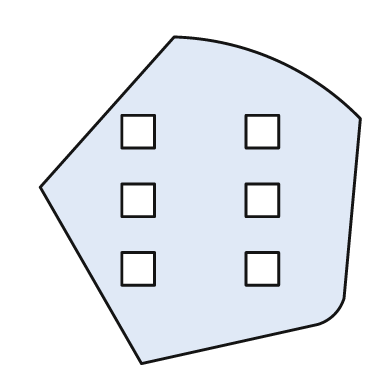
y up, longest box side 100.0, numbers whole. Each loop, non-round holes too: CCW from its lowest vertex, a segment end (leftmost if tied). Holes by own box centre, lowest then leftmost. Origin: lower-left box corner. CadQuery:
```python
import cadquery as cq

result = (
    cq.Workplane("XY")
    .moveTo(31.0, 0.0)
    .lineTo(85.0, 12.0)
    .threePointArc((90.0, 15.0), (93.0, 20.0))
    .lineTo(98.0, 75.0)
    .threePointArc((72.0, 93.0), (41.0, 100.0))
    .lineTo(0.0, 54.0)
    .close()
    .moveTo(25.0, 24.0)
    .lineTo(35.0, 24.0)
    .lineTo(35.0, 34.0)
    .lineTo(25.0, 34.0)
    .close()
    .moveTo(63.0, 24.0)
    .lineTo(73.0, 24.0)
    .lineTo(73.0, 34.0)
    .lineTo(63.0, 34.0)
    .close()
    .moveTo(25.0, 45.0)
    .lineTo(35.0, 45.0)
    .lineTo(35.0, 55.0)
    .lineTo(25.0, 55.0)
    .close()
    .moveTo(63.0, 45.0)
    .lineTo(73.0, 45.0)
    .lineTo(73.0, 55.0)
    .lineTo(63.0, 55.0)
    .close()
    .moveTo(25.0, 66.0)
    .lineTo(35.0, 66.0)
    .lineTo(35.0, 76.0)
    .lineTo(25.0, 76.0)
    .close()
    .moveTo(63.0, 66.0)
    .lineTo(73.0, 66.0)
    .lineTo(73.0, 76.0)
    .lineTo(63.0, 76.0)
    .close()
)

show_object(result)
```